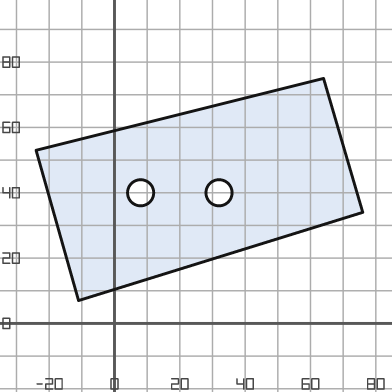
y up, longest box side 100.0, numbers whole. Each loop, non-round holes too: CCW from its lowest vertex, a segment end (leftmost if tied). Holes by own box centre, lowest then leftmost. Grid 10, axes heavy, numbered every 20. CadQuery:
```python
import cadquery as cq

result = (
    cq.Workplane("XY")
    .moveTo(-11.0, 7.0)
    .lineTo(76.0, 34.0)
    .lineTo(64.0, 75.0)
    .lineTo(-24.0, 53.0)
    .close()
    .moveTo(8.0, 40.0)
    .circle(4.0)
    .moveTo(32.0, 40.0)
    .circle(4.0)
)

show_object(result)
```